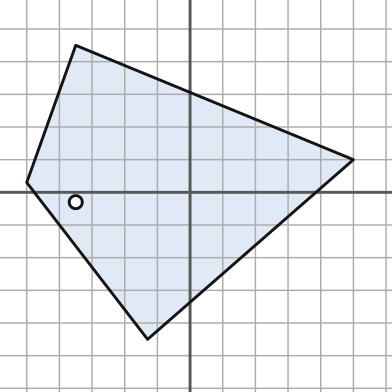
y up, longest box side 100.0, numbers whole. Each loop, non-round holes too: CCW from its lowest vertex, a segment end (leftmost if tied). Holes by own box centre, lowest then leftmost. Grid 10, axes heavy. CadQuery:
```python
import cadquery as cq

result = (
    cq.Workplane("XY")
    .moveTo(-13.0, -45.0)
    .lineTo(50.0, 10.0)
    .lineTo(-35.0, 45.0)
    .lineTo(-50.0, 3.0)
    .close()
    .moveTo(-35.0, -3.0)
    .circle(2.0)
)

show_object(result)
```